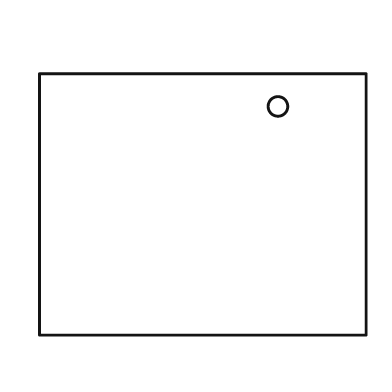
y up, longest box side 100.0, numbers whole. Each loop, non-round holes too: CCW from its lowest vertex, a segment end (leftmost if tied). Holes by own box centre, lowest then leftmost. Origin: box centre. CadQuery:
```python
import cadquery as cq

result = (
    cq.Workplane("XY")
    .moveTo(-50.0, -40.0)
    .lineTo(50.0, -40.0)
    .lineTo(50.0, 40.0)
    .lineTo(-50.0, 40.0)
    .close()
    .moveTo(23.0, 30.0)
    .circle(3.0)
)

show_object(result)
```